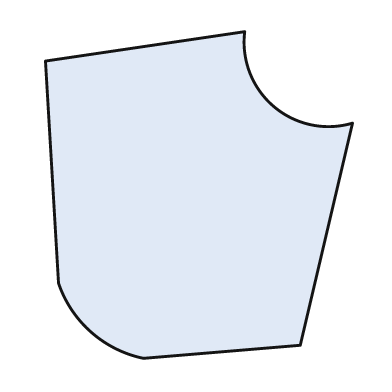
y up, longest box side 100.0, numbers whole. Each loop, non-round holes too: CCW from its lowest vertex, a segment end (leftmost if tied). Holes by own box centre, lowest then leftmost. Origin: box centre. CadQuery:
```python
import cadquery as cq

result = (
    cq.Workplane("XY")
    .moveTo(-17.0, -50.0)
    .lineTo(31.0, -46.0)
    .lineTo(47.0, 22.0)
    .threePointArc((23.0, 27.0), (14.0, 50.0))
    .lineTo(-47.0, 41.0)
    .lineTo(-43.0, -27.0)
    .threePointArc((-33.0, -42.0), (-17.0, -50.0))
    .close()
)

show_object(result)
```